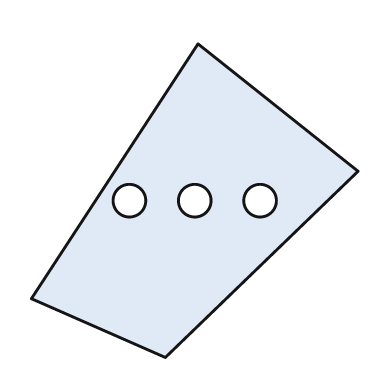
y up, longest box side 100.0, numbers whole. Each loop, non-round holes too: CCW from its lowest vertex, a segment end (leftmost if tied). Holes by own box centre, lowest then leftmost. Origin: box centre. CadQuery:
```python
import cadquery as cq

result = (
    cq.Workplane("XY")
    .moveTo(-9.0, -48.0)
    .lineTo(50.0, 9.0)
    .lineTo(1.0, 48.0)
    .lineTo(-50.0, -30.0)
    .close()
    .moveTo(-20.0, 0.0)
    .circle(5.0)
    .moveTo(0.0, 0.0)
    .circle(5.0)
    .moveTo(20.0, 0.0)
    .circle(5.0)
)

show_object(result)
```